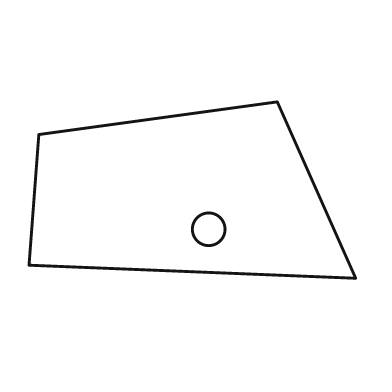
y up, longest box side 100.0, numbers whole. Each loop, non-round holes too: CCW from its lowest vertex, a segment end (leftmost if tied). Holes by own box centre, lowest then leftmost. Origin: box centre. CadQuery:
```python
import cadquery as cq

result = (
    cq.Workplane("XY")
    .moveTo(50.0, -27.0)
    .lineTo(26.0, 27.0)
    .lineTo(-47.0, 17.0)
    .lineTo(-50.0, -23.0)
    .close()
    .moveTo(5.0, -12.0)
    .circle(5.0)
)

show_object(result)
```